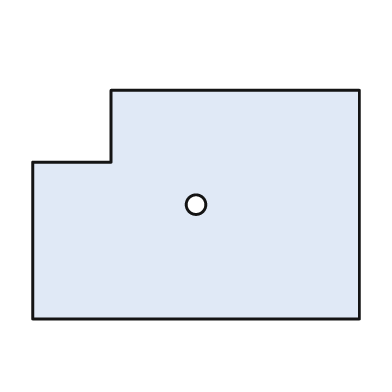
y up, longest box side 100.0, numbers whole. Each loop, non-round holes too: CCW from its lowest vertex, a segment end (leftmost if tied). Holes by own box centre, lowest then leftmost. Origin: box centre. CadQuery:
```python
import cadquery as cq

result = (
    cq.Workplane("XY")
    .moveTo(-50.0, -35.0)
    .lineTo(50.0, -35.0)
    .lineTo(50.0, 35.0)
    .lineTo(-26.0, 35.0)
    .lineTo(-26.0, 13.0)
    .lineTo(-50.0, 13.0)
    .close()
    .moveTo(0.0, 0.0)
    .circle(3.0)
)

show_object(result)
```